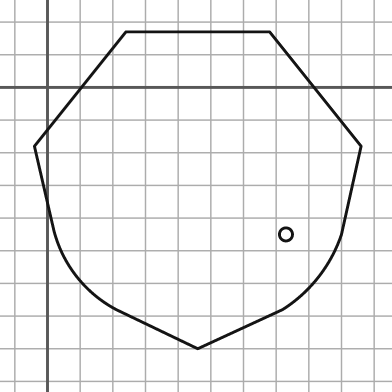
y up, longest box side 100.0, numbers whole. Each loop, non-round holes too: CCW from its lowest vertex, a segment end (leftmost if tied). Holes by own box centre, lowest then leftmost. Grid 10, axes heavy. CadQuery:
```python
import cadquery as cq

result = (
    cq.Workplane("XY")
    .moveTo(46.0, -80.0)
    .lineTo(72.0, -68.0)
    .threePointArc((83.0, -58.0), (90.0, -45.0))
    .lineTo(96.0, -18.0)
    .lineTo(68.0, 17.0)
    .lineTo(24.0, 17.0)
    .lineTo(-4.0, -18.0)
    .lineTo(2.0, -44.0)
    .threePointArc((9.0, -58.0), (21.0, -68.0))
    .close()
    .moveTo(73.0, -45.0)
    .circle(2.0)
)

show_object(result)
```